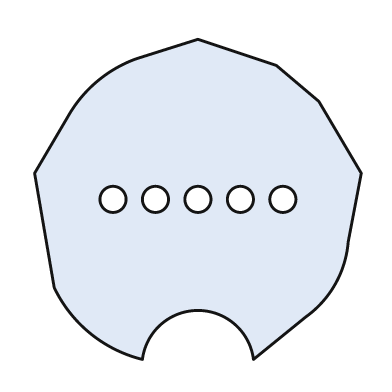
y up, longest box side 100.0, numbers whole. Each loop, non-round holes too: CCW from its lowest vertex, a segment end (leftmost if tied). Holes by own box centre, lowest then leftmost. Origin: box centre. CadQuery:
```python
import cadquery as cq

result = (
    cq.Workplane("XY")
    .moveTo(-17.0, -49.0)
    .threePointArc((0.0, -34.0), (17.0, -49.0))
    .lineTo(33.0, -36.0)
    .threePointArc((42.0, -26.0), (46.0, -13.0))
    .lineTo(50.0, 8.0)
    .lineTo(37.0, 30.0)
    .lineTo(24.0, 41.0)
    .lineTo(0.0, 49.0)
    .lineTo(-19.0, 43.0)
    .threePointArc((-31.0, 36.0), (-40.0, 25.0))
    .lineTo(-50.0, 8.0)
    .lineTo(-44.0, -27.0)
    .threePointArc((-33.0, -41.0), (-17.0, -49.0))
    .close()
    .moveTo(-26.0, 0.0)
    .circle(4.0)
    .moveTo(-13.0, 0.0)
    .circle(4.0)
    .moveTo(0.0, 0.0)
    .circle(4.0)
    .moveTo(13.0, 0.0)
    .circle(4.0)
    .moveTo(26.0, 0.0)
    .circle(4.0)
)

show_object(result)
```